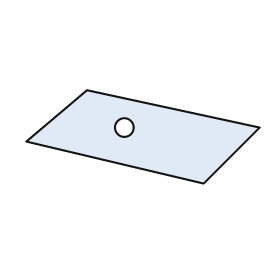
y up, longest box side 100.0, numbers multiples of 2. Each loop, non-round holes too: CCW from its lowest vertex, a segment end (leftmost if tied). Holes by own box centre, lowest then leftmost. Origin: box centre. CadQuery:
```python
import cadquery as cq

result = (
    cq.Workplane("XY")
    .moveTo(26.0, -20.0)
    .lineTo(50.0, 4.0)
    .lineTo(-24.0, 20.0)
    .lineTo(-50.0, -2.0)
    .close()
    .moveTo(-8.0, 4.0)
    .circle(4.0)
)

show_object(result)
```